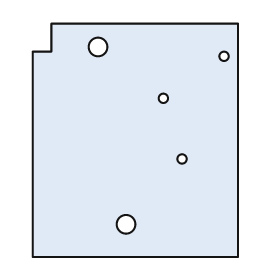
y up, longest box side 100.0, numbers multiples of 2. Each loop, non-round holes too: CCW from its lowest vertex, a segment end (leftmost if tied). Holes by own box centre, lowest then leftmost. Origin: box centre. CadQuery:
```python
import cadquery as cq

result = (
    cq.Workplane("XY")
    .moveTo(-44.0, -50.0)
    .lineTo(44.0, -50.0)
    .lineTo(44.0, 50.0)
    .lineTo(-36.0, 50.0)
    .lineTo(-36.0, 38.0)
    .lineTo(-44.0, 38.0)
    .close()
    .moveTo(-4.0, -36.0)
    .circle(4.0)
    .moveTo(20.0, -8.0)
    .circle(2.0)
    .moveTo(12.0, 18.0)
    .circle(2.0)
    .moveTo(38.0, 36.0)
    .circle(2.0)
    .moveTo(-16.0, 40.0)
    .circle(4.0)
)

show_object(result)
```